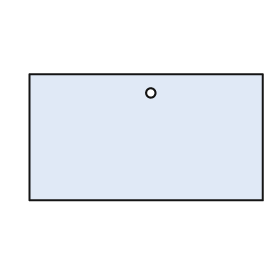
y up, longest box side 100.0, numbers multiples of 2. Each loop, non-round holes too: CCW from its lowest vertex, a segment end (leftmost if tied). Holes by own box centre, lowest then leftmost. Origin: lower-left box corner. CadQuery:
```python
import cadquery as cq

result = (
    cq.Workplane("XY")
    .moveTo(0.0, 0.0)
    .lineTo(100.0, 0.0)
    .lineTo(100.0, 54.0)
    .lineTo(0.0, 54.0)
    .close()
    .moveTo(52.0, 46.0)
    .circle(2.0)
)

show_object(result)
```